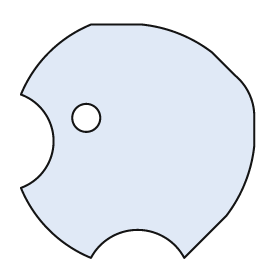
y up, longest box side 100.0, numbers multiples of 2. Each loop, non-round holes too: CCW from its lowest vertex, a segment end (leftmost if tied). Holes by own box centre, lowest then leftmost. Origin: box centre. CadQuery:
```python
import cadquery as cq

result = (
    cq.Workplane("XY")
    .moveTo(-20.0, -50.0)
    .threePointArc((0.0, -38.0), (20.0, -50.0))
    .lineTo(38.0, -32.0)
    .threePointArc((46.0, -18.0), (50.0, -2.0))
    .lineTo(50.0, 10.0)
    .threePointArc((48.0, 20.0), (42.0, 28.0))
    .lineTo(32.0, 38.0)
    .threePointArc((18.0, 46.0), (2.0, 50.0))
    .lineTo(-20.0, 50.0)
    .threePointArc((-38.0, 38.0), (-50.0, 20.0))
    .threePointArc((-36.0, 0.0), (-50.0, -20.0))
    .threePointArc((-38.0, -38.0), (-20.0, -50.0))
    .close()
    .moveTo(-22.0, 10.0)
    .circle(6.0)
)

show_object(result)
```